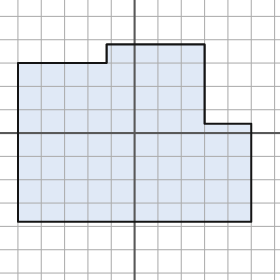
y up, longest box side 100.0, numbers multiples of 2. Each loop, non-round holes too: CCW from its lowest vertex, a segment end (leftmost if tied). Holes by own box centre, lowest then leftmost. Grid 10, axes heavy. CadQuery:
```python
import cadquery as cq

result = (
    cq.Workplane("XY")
    .moveTo(-50.0, -38.0)
    .lineTo(50.0, -38.0)
    .lineTo(50.0, 4.0)
    .lineTo(30.0, 4.0)
    .lineTo(30.0, 38.0)
    .lineTo(-12.0, 38.0)
    .lineTo(-12.0, 30.0)
    .lineTo(-50.0, 30.0)
    .close()
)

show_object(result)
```